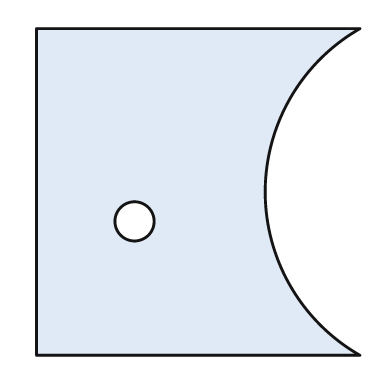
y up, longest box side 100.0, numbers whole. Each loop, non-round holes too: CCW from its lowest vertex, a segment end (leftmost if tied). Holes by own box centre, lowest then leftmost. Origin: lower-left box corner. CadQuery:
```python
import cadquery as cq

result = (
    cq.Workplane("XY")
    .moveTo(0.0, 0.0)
    .lineTo(99.0, 0.0)
    .threePointArc((70.0, 50.0), (99.0, 100.0))
    .lineTo(0.0, 100.0)
    .close()
    .moveTo(30.0, 41.0)
    .circle(6.0)
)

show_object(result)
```